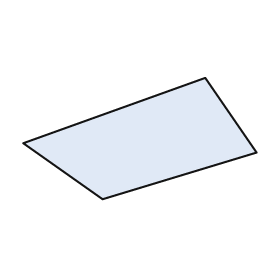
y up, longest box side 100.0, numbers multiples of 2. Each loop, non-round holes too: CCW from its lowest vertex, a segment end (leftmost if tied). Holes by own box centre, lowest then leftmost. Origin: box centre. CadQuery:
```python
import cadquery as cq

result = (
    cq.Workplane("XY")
    .moveTo(-16.0, -26.0)
    .lineTo(50.0, -6.0)
    .lineTo(28.0, 26.0)
    .lineTo(-50.0, -2.0)
    .close()
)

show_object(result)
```